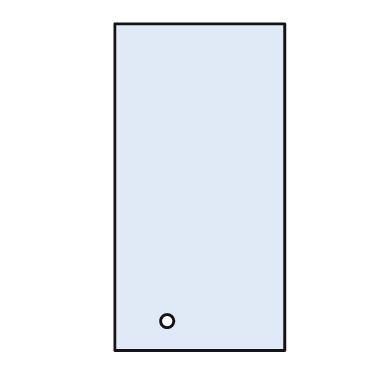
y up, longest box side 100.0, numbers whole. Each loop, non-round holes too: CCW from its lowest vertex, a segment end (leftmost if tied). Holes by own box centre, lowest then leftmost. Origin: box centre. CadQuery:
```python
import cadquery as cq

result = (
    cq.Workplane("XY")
    .moveTo(-26.0, -50.0)
    .lineTo(26.0, -50.0)
    .lineTo(26.0, 50.0)
    .lineTo(-26.0, 50.0)
    .close()
    .moveTo(-10.0, -41.0)
    .circle(2.0)
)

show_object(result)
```